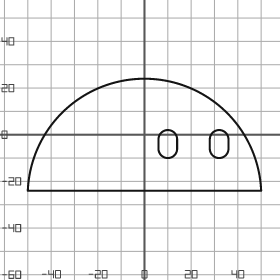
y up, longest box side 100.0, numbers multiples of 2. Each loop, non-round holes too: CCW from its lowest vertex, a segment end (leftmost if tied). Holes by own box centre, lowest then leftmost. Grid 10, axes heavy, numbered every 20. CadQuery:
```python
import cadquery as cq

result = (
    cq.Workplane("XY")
    .moveTo(-50.0, -24.0)
    .lineTo(50.0, -24.0)
    .threePointArc((0.0, 24.0), (-50.0, -24.0))
    .close()
    .moveTo(6.0, -6.0)
    .threePointArc((10.0, -10.0), (14.0, -6.0))
    .lineTo(14.0, -2.0)
    .threePointArc((10.0, 2.0), (6.0, -2.0))
    .close()
    .moveTo(28.0, -6.0)
    .threePointArc((32.0, -10.0), (36.0, -6.0))
    .lineTo(36.0, -2.0)
    .threePointArc((32.0, 2.0), (28.0, -2.0))
    .close()
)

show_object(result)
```